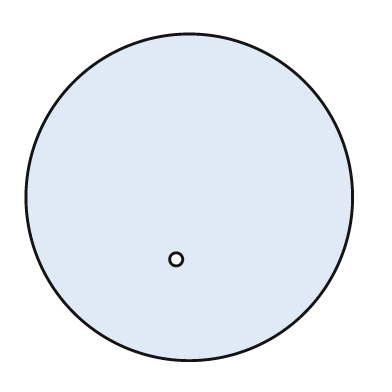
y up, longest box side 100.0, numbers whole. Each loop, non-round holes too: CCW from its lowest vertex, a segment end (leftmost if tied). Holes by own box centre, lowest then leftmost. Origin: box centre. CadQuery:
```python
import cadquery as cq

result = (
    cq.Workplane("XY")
    .moveTo(0.0, 0.0)
    .circle(50.0)
    .moveTo(-4.0, -19.0)
    .circle(2.0)
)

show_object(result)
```